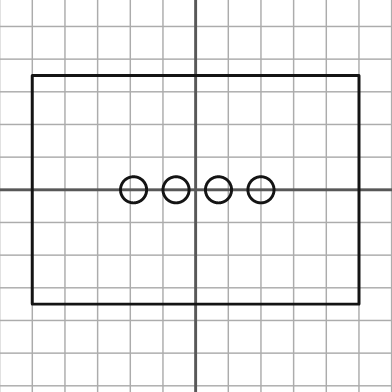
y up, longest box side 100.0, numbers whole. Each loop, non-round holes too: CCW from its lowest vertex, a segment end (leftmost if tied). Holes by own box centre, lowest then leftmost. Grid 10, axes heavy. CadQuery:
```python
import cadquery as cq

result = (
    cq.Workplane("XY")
    .moveTo(-50.0, -35.0)
    .lineTo(50.0, -35.0)
    .lineTo(50.0, 35.0)
    .lineTo(-50.0, 35.0)
    .close()
    .moveTo(-19.0, 0.0)
    .circle(4.0)
    .moveTo(-6.0, 0.0)
    .circle(4.0)
    .moveTo(7.0, 0.0)
    .circle(4.0)
    .moveTo(20.0, 0.0)
    .circle(4.0)
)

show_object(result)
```